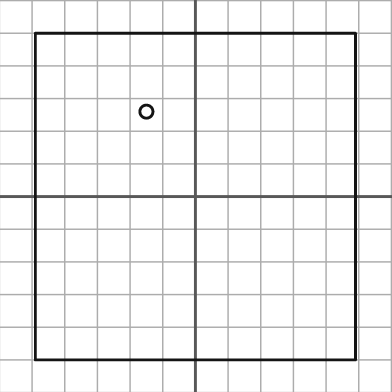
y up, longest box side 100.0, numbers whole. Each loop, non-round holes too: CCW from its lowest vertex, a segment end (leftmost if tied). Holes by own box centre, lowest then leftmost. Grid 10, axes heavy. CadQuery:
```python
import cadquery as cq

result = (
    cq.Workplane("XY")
    .moveTo(-49.0, -50.0)
    .lineTo(49.0, -50.0)
    .lineTo(49.0, 50.0)
    .lineTo(-49.0, 50.0)
    .close()
    .moveTo(-15.0, 26.0)
    .circle(2.0)
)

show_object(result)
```